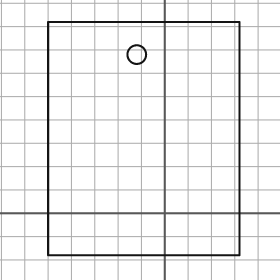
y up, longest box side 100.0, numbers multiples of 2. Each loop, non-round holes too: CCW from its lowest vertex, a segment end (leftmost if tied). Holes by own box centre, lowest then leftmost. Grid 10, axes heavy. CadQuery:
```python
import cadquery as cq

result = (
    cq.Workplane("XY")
    .moveTo(-50.0, -18.0)
    .lineTo(32.0, -18.0)
    .lineTo(32.0, 82.0)
    .lineTo(-50.0, 82.0)
    .close()
    .moveTo(-12.0, 68.0)
    .circle(4.0)
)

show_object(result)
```